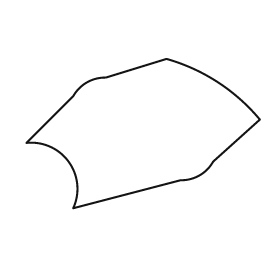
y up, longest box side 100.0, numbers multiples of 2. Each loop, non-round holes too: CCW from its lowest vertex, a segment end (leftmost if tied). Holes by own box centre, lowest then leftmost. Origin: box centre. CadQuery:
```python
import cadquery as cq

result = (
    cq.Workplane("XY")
    .moveTo(-30.0, -32.0)
    .lineTo(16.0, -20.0)
    .threePointArc((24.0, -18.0), (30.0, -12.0))
    .lineTo(50.0, 6.0)
    .threePointArc((32.0, 22.0), (10.0, 32.0))
    .lineTo(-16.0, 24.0)
    .threePointArc((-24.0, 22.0), (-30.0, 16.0))
    .lineTo(-50.0, -4.0)
    .threePointArc((-32.0, -12.0), (-30.0, -32.0))
    .close()
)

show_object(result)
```